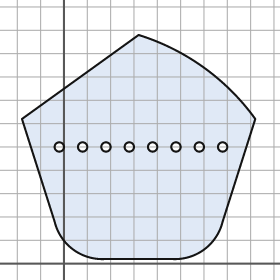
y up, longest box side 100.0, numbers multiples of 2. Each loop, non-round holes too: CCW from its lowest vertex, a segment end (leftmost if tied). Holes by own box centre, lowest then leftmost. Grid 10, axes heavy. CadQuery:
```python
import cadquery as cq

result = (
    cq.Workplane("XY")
    .moveTo(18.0, 2.0)
    .lineTo(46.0, 2.0)
    .threePointArc((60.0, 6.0), (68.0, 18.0))
    .lineTo(82.0, 62.0)
    .threePointArc((60.0, 84.0), (32.0, 98.0))
    .lineTo(-18.0, 62.0)
    .lineTo(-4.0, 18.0)
    .threePointArc((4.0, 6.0), (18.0, 2.0))
    .close()
    .moveTo(-2.0, 50.0)
    .circle(2.0)
    .moveTo(8.0, 50.0)
    .circle(2.0)
    .moveTo(18.0, 50.0)
    .circle(2.0)
    .moveTo(28.0, 50.0)
    .circle(2.0)
    .moveTo(38.0, 50.0)
    .circle(2.0)
    .moveTo(48.0, 50.0)
    .circle(2.0)
    .moveTo(58.0, 50.0)
    .circle(2.0)
    .moveTo(68.0, 50.0)
    .circle(2.0)
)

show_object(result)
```